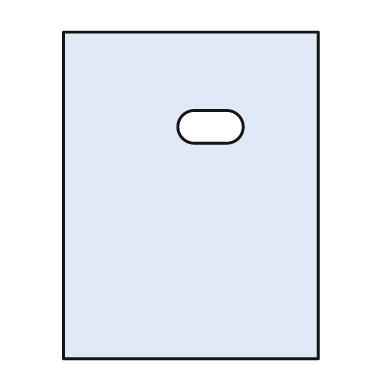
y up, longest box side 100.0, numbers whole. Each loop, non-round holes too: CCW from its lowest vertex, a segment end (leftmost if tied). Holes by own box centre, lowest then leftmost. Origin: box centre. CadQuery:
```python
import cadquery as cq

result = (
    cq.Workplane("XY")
    .moveTo(-39.0, -50.0)
    .lineTo(39.0, -50.0)
    .lineTo(39.0, 50.0)
    .lineTo(-39.0, 50.0)
    .close()
    .moveTo(1.0, 16.0)
    .lineTo(11.0, 16.0)
    .threePointArc((16.0, 21.0), (11.0, 26.0))
    .lineTo(1.0, 26.0)
    .threePointArc((-4.0, 21.0), (1.0, 16.0))
    .close()
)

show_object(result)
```